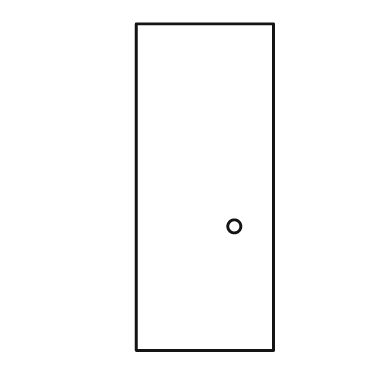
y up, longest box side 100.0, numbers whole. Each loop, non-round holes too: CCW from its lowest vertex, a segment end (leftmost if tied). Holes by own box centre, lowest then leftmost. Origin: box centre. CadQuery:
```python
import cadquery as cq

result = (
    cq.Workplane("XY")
    .moveTo(-21.0, -50.0)
    .lineTo(21.0, -50.0)
    .lineTo(21.0, 50.0)
    .lineTo(-21.0, 50.0)
    .close()
    .moveTo(9.0, -12.0)
    .circle(2.0)
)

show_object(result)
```